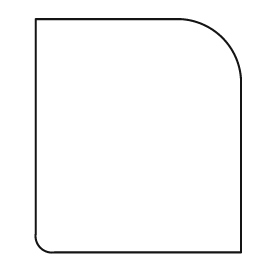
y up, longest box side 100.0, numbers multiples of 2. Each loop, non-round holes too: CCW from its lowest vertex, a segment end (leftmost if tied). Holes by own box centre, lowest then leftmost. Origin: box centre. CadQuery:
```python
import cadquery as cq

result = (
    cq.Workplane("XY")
    .moveTo(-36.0, -50.0)
    .lineTo(44.0, -50.0)
    .lineTo(44.0, 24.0)
    .threePointArc((36.0, 42.0), (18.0, 50.0))
    .lineTo(-44.0, 50.0)
    .lineTo(-44.0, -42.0)
    .threePointArc((-42.0, -48.0), (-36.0, -50.0))
    .close()
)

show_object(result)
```